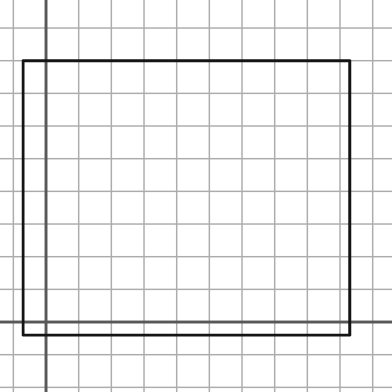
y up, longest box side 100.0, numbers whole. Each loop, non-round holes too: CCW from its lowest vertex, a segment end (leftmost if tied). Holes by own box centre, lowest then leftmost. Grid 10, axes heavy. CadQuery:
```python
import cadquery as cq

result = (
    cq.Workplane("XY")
    .moveTo(-7.0, -4.0)
    .lineTo(93.0, -4.0)
    .lineTo(93.0, 80.0)
    .lineTo(-7.0, 80.0)
    .close()
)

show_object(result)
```